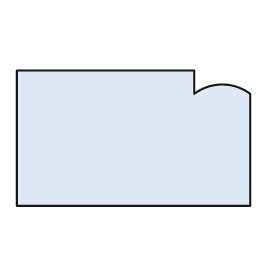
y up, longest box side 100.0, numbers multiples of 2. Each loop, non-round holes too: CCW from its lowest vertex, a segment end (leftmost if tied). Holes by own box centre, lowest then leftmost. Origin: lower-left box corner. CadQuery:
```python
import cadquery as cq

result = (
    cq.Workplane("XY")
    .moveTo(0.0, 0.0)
    .lineTo(100.0, 0.0)
    .lineTo(100.0, 48.0)
    .threePointArc((88.0, 52.0), (76.0, 48.0))
    .lineTo(76.0, 58.0)
    .lineTo(0.0, 58.0)
    .close()
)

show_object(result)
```